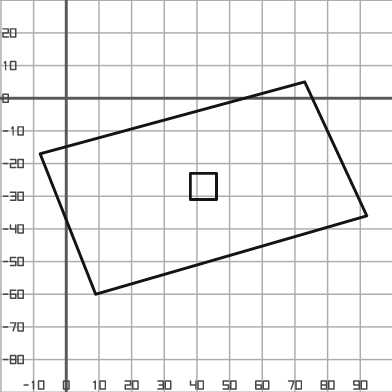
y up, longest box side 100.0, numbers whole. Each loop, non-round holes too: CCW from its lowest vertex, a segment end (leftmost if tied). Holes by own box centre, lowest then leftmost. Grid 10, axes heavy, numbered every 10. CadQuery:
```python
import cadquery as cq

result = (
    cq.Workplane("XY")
    .moveTo(9.0, -60.0)
    .lineTo(92.0, -36.0)
    .lineTo(73.0, 5.0)
    .lineTo(-8.0, -17.0)
    .close()
    .moveTo(38.0, -31.0)
    .lineTo(46.0, -31.0)
    .lineTo(46.0, -23.0)
    .lineTo(38.0, -23.0)
    .close()
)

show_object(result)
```